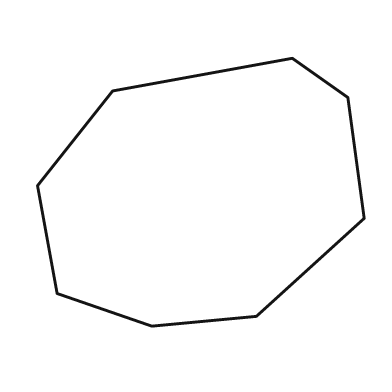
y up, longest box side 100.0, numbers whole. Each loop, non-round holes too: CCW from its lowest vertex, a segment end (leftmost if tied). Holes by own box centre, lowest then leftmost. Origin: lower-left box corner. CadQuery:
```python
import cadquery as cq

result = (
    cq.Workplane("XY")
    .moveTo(35.0, 0.0)
    .lineTo(67.0, 3.0)
    .lineTo(100.0, 33.0)
    .lineTo(95.0, 70.0)
    .lineTo(78.0, 82.0)
    .lineTo(23.0, 72.0)
    .lineTo(0.0, 43.0)
    .lineTo(6.0, 10.0)
    .close()
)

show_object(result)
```